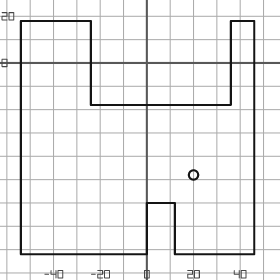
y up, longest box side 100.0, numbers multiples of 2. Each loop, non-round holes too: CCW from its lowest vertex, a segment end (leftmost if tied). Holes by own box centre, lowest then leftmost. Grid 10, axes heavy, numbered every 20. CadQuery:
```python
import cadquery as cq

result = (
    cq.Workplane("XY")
    .moveTo(-54.0, -82.0)
    .lineTo(0.0, -82.0)
    .lineTo(0.0, -60.0)
    .lineTo(12.0, -60.0)
    .lineTo(12.0, -82.0)
    .lineTo(46.0, -82.0)
    .lineTo(46.0, 18.0)
    .lineTo(36.0, 18.0)
    .lineTo(36.0, -18.0)
    .lineTo(-24.0, -18.0)
    .lineTo(-24.0, 18.0)
    .lineTo(-54.0, 18.0)
    .close()
    .moveTo(20.0, -48.0)
    .circle(2.0)
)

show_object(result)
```